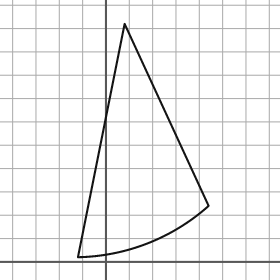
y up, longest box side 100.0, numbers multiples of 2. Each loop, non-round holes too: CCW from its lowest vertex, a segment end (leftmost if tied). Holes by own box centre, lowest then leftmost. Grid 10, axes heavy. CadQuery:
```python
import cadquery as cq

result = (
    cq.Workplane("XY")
    .moveTo(-12.0, 2.0)
    .threePointArc((18.0, 8.0), (44.0, 24.0))
    .lineTo(8.0, 102.0)
    .close()
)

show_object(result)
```